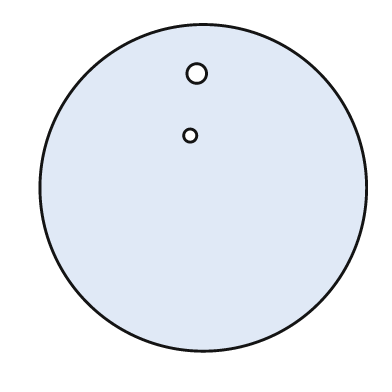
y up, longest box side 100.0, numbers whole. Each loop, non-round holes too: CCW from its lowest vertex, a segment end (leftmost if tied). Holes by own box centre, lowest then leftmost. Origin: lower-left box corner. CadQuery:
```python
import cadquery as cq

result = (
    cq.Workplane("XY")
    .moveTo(50.0, 50.0)
    .circle(50.0)
    .moveTo(46.0, 66.0)
    .circle(2.0)
    .moveTo(48.0, 85.0)
    .circle(3.0)
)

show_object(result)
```